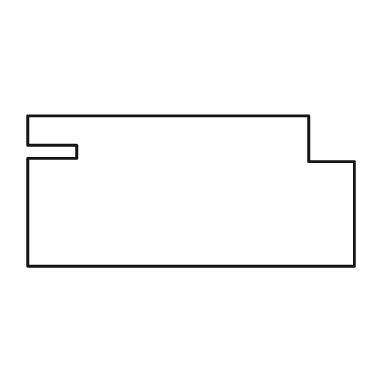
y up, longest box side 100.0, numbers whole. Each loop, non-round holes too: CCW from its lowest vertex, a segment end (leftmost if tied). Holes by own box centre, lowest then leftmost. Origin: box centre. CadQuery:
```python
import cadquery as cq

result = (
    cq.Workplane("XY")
    .moveTo(-50.0, -23.0)
    .lineTo(50.0, -23.0)
    .lineTo(50.0, 9.0)
    .lineTo(36.0, 9.0)
    .lineTo(36.0, 23.0)
    .lineTo(-50.0, 23.0)
    .lineTo(-50.0, 14.0)
    .lineTo(-35.0, 14.0)
    .lineTo(-35.0, 10.0)
    .lineTo(-50.0, 10.0)
    .close()
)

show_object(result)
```